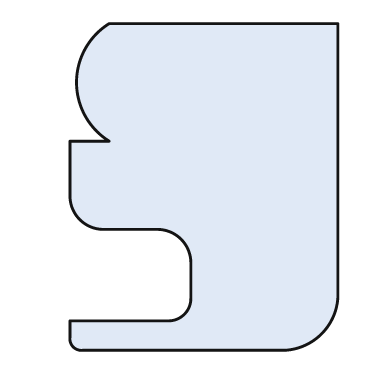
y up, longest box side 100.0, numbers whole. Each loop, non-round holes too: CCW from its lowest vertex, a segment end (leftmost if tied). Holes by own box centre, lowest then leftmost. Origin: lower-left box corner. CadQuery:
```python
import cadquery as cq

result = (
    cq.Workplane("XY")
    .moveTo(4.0, 0.0)
    .lineTo(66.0, 0.0)
    .threePointArc((77.0, 5.0), (82.0, 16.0))
    .lineTo(82.0, 100.0)
    .lineTo(12.0, 100.0)
    .threePointArc((2.0, 82.0), (12.0, 64.0))
    .lineTo(0.0, 64.0)
    .lineTo(0.0, 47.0)
    .threePointArc((3.0, 40.0), (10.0, 37.0))
    .lineTo(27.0, 37.0)
    .threePointArc((34.0, 34.0), (37.0, 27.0))
    .lineTo(37.0, 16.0)
    .threePointArc((35.0, 11.0), (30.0, 9.0))
    .lineTo(0.0, 9.0)
    .lineTo(0.0, 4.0)
    .threePointArc((1.0, 1.0), (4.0, 0.0))
    .close()
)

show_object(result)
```